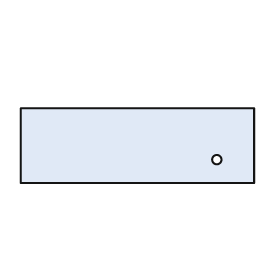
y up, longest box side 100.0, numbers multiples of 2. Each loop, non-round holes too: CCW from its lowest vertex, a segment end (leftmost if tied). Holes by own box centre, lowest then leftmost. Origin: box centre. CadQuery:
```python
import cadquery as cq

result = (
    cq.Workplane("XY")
    .moveTo(-50.0, -16.0)
    .lineTo(50.0, -16.0)
    .lineTo(50.0, 16.0)
    .lineTo(-50.0, 16.0)
    .close()
    .moveTo(34.0, -6.0)
    .circle(2.0)
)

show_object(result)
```